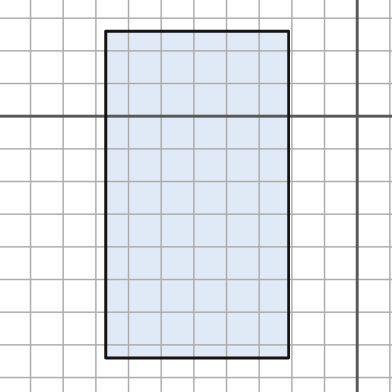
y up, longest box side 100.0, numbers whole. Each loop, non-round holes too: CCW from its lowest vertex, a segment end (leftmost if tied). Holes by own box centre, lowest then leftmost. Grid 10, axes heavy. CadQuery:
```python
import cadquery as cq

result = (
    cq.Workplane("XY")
    .moveTo(-77.0, -74.0)
    .lineTo(-21.0, -74.0)
    .lineTo(-21.0, 26.0)
    .lineTo(-77.0, 26.0)
    .close()
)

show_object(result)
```